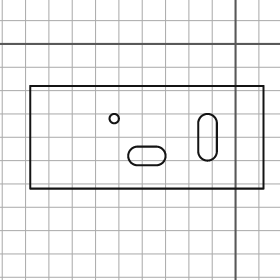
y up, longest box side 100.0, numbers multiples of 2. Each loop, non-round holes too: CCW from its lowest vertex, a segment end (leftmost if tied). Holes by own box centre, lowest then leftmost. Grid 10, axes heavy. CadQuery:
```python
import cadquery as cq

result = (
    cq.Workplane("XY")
    .moveTo(-88.0, -62.0)
    .lineTo(12.0, -62.0)
    .lineTo(12.0, -18.0)
    .lineTo(-88.0, -18.0)
    .close()
    .moveTo(-42.0, -52.0)
    .lineTo(-34.0, -52.0)
    .threePointArc((-30.0, -48.0), (-34.0, -44.0))
    .lineTo(-42.0, -44.0)
    .threePointArc((-46.0, -48.0), (-42.0, -52.0))
    .close()
    .moveTo(-16.0, -46.0)
    .threePointArc((-12.0, -50.0), (-8.0, -46.0))
    .lineTo(-8.0, -34.0)
    .threePointArc((-12.0, -30.0), (-16.0, -34.0))
    .close()
    .moveTo(-52.0, -32.0)
    .circle(2.0)
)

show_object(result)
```